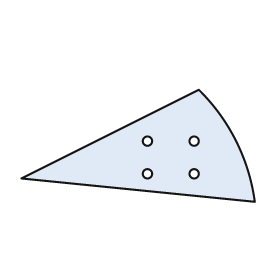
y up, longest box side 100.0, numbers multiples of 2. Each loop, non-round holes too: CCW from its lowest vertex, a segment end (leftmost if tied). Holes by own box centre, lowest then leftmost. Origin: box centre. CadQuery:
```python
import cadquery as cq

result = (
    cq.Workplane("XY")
    .moveTo(50.0, -24.0)
    .threePointArc((42.0, 2.0), (26.0, 24.0))
    .lineTo(-50.0, -14.0)
    .close()
    .moveTo(4.0, -12.0)
    .circle(2.0)
    .moveTo(24.0, -12.0)
    .circle(2.0)
    .moveTo(4.0, 2.0)
    .circle(2.0)
    .moveTo(24.0, 2.0)
    .circle(2.0)
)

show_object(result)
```